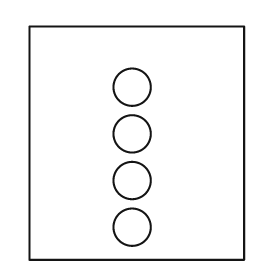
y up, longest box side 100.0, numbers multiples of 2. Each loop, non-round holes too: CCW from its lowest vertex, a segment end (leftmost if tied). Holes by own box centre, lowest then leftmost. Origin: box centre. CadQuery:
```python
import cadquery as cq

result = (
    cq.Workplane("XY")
    .moveTo(-46.0, -50.0)
    .lineTo(46.0, -50.0)
    .lineTo(46.0, 50.0)
    .lineTo(-46.0, 50.0)
    .close()
    .moveTo(-2.0, -36.0)
    .circle(8.0)
    .moveTo(-2.0, -16.0)
    .circle(8.0)
    .moveTo(-2.0, 4.0)
    .circle(8.0)
    .moveTo(-2.0, 24.0)
    .circle(8.0)
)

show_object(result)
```